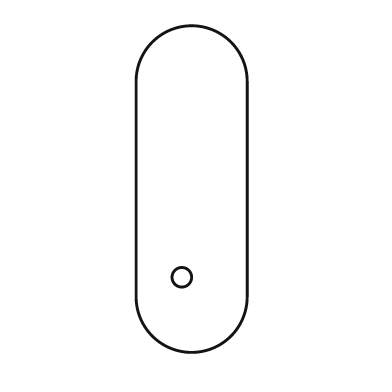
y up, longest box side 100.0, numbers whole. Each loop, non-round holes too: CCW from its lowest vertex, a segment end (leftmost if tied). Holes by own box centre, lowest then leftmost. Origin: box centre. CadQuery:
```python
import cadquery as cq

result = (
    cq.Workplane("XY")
    .moveTo(-17.0, -33.0)
    .threePointArc((0.0, -50.0), (17.0, -33.0))
    .lineTo(17.0, 33.0)
    .threePointArc((0.0, 50.0), (-17.0, 33.0))
    .close()
    .moveTo(-3.0, -27.0)
    .circle(3.0)
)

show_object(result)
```